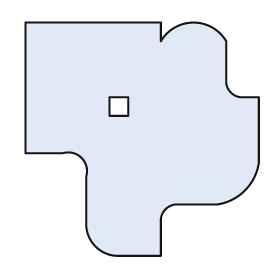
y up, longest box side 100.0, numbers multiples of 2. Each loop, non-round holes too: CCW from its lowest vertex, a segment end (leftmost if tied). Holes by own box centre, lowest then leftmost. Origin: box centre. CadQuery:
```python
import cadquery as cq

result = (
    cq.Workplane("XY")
    .moveTo(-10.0, -50.0)
    .lineTo(8.0, -50.0)
    .lineTo(8.0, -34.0)
    .threePointArc((10.0, -30.0), (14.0, -28.0))
    .lineTo(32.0, -28.0)
    .threePointArc((44.0, -22.0), (50.0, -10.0))
    .lineTo(50.0, 18.0)
    .lineTo(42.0, 18.0)
    .threePointArc((38.0, 20.0), (36.0, 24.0))
    .lineTo(36.0, 42.0)
    .threePointArc((22.0, 50.0), (8.0, 42.0))
    .lineTo(8.0, 50.0)
    .lineTo(-50.0, 50.0)
    .lineTo(-50.0, -6.0)
    .lineTo(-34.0, -6.0)
    .threePointArc((-26.0, -8.0), (-24.0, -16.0))
    .lineTo(-24.0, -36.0)
    .threePointArc((-20.0, -46.0), (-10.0, -50.0))
    .close()
    .moveTo(-14.0, 10.0)
    .lineTo(-6.0, 10.0)
    .lineTo(-6.0, 18.0)
    .lineTo(-14.0, 18.0)
    .close()
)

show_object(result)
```